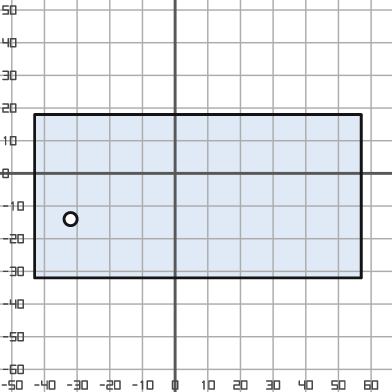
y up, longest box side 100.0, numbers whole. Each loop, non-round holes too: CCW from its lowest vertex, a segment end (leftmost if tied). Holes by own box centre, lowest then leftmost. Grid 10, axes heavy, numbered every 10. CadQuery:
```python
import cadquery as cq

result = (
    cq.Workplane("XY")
    .moveTo(-43.0, -32.0)
    .lineTo(57.0, -32.0)
    .lineTo(57.0, 18.0)
    .lineTo(-43.0, 18.0)
    .close()
    .moveTo(-32.0, -14.0)
    .circle(2.0)
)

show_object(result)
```